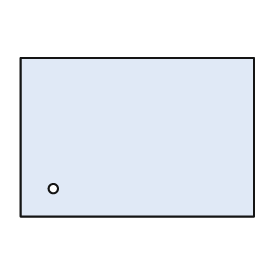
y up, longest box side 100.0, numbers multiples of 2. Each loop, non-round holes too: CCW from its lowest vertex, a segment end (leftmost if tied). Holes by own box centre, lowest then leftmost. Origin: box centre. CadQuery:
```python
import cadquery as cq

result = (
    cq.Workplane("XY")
    .moveTo(-50.0, -34.0)
    .lineTo(50.0, -34.0)
    .lineTo(50.0, 34.0)
    .lineTo(-50.0, 34.0)
    .close()
    .moveTo(-36.0, -22.0)
    .circle(2.0)
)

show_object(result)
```